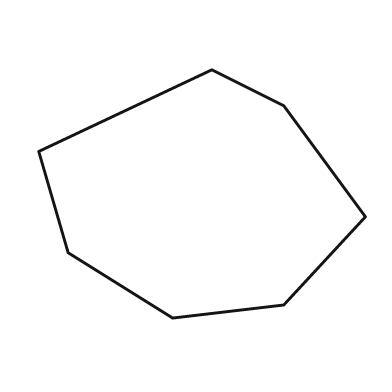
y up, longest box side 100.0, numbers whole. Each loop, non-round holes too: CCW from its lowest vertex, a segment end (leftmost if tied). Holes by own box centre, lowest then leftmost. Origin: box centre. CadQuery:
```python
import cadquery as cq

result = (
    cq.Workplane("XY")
    .moveTo(-9.0, -38.0)
    .lineTo(25.0, -34.0)
    .lineTo(50.0, -7.0)
    .lineTo(25.0, 27.0)
    .lineTo(3.0, 38.0)
    .lineTo(-50.0, 13.0)
    .lineTo(-41.0, -18.0)
    .close()
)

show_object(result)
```